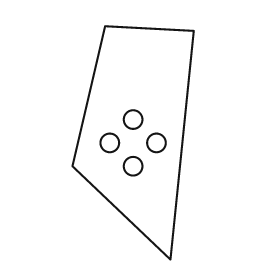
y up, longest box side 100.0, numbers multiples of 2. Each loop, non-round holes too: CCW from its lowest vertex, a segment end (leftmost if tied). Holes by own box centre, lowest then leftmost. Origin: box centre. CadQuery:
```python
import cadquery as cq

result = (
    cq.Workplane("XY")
    .moveTo(16.0, -50.0)
    .lineTo(26.0, 48.0)
    .lineTo(-12.0, 50.0)
    .lineTo(-26.0, -10.0)
    .close()
    .moveTo(0.0, -10.0)
    .circle(4.0)
    .moveTo(-10.0, 0.0)
    .circle(4.0)
    .moveTo(10.0, 0.0)
    .circle(4.0)
    .moveTo(0.0, 10.0)
    .circle(4.0)
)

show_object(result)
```